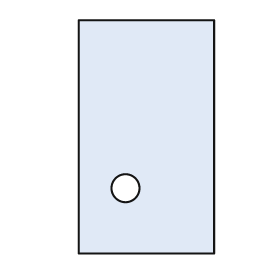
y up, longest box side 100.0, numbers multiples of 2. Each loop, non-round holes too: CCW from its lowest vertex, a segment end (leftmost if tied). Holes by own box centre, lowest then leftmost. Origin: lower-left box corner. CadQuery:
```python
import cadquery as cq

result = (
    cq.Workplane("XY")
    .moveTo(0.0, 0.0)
    .lineTo(58.0, 0.0)
    .lineTo(58.0, 100.0)
    .lineTo(0.0, 100.0)
    .close()
    .moveTo(20.0, 28.0)
    .circle(6.0)
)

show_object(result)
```